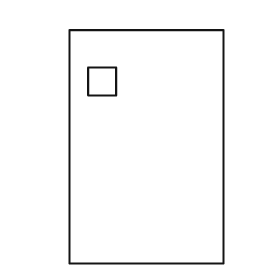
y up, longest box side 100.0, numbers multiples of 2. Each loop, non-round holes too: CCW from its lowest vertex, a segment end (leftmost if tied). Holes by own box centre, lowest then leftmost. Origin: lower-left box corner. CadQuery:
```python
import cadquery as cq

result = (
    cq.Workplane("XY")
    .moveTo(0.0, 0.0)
    .lineTo(66.0, 0.0)
    .lineTo(66.0, 100.0)
    .lineTo(0.0, 100.0)
    .close()
    .moveTo(8.0, 72.0)
    .lineTo(20.0, 72.0)
    .lineTo(20.0, 84.0)
    .lineTo(8.0, 84.0)
    .close()
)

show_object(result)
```